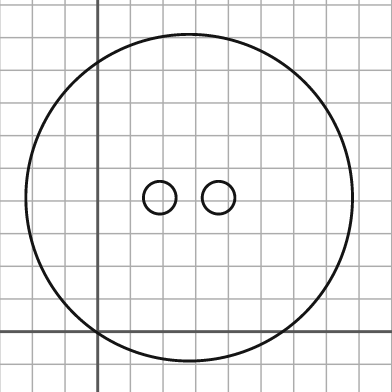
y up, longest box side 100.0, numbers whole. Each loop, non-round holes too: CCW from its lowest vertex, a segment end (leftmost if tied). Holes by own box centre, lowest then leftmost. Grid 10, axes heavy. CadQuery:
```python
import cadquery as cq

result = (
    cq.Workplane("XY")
    .moveTo(28.0, 41.0)
    .circle(50.0)
    .moveTo(19.0, 41.0)
    .circle(5.0)
    .moveTo(37.0, 41.0)
    .circle(5.0)
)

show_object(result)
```